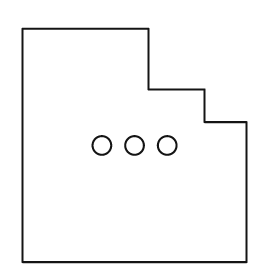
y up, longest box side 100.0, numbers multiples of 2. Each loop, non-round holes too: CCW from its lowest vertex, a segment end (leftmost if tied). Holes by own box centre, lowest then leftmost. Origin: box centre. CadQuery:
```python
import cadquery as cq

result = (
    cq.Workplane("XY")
    .moveTo(-48.0, -50.0)
    .lineTo(48.0, -50.0)
    .lineTo(48.0, 10.0)
    .lineTo(30.0, 10.0)
    .lineTo(30.0, 24.0)
    .lineTo(6.0, 24.0)
    .lineTo(6.0, 50.0)
    .lineTo(-48.0, 50.0)
    .close()
    .moveTo(-14.0, 0.0)
    .circle(4.0)
    .moveTo(0.0, 0.0)
    .circle(4.0)
    .moveTo(14.0, 0.0)
    .circle(4.0)
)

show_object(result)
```